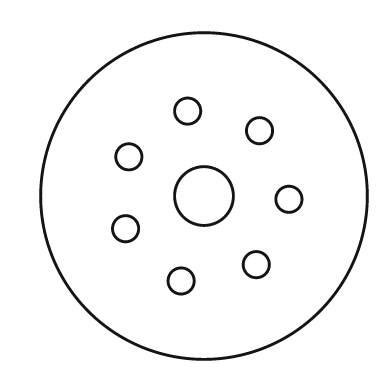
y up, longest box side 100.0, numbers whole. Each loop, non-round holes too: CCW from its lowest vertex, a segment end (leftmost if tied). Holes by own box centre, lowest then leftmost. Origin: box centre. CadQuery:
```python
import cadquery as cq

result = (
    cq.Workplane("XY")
    .moveTo(0.0, 0.0)
    .circle(50.0)
    .moveTo(-7.0, -26.0)
    .circle(4.0)
    .moveTo(16.0, -21.0)
    .circle(4.0)
    .moveTo(-24.0, -10.0)
    .circle(4.0)
    .moveTo(26.0, -1.0)
    .circle(4.0)
    .moveTo(0.0, 0.0)
    .circle(9.0)
    .moveTo(-23.0, 12.0)
    .circle(4.0)
    .moveTo(17.0, 20.0)
    .circle(4.0)
    .moveTo(-5.0, 26.0)
    .circle(4.0)
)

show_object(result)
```